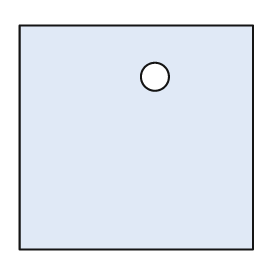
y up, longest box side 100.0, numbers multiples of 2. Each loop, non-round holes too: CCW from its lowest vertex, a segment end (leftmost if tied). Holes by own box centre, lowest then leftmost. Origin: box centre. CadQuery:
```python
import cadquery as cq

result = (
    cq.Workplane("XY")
    .moveTo(-50.0, -48.0)
    .lineTo(50.0, -48.0)
    .lineTo(50.0, 48.0)
    .lineTo(-50.0, 48.0)
    .close()
    .moveTo(8.0, 26.0)
    .circle(6.0)
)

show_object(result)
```